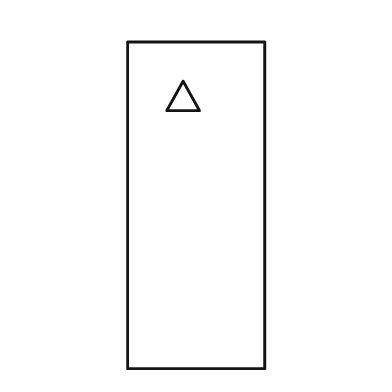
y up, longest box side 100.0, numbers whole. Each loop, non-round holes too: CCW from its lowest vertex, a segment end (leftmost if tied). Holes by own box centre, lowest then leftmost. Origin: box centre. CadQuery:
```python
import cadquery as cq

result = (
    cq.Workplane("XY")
    .moveTo(-21.0, -50.0)
    .lineTo(21.0, -50.0)
    .lineTo(21.0, 50.0)
    .lineTo(-21.0, 50.0)
    .close()
    .moveTo(-9.0, 29.0)
    .lineTo(1.0, 29.0)
    .lineTo(-4.0, 38.0)
    .close()
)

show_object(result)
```